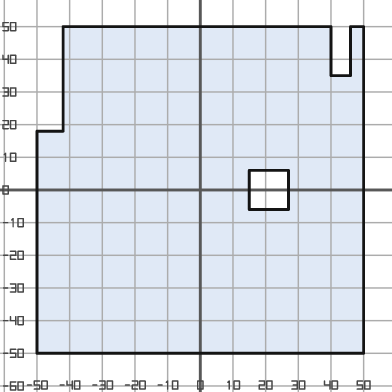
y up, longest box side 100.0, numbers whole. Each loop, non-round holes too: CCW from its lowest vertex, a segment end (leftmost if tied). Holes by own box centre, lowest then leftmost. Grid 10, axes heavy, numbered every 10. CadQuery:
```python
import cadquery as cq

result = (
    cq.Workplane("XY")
    .moveTo(-50.0, -50.0)
    .lineTo(50.0, -50.0)
    .lineTo(50.0, 50.0)
    .lineTo(46.0, 50.0)
    .lineTo(46.0, 35.0)
    .lineTo(40.0, 35.0)
    .lineTo(40.0, 50.0)
    .lineTo(-42.0, 50.0)
    .lineTo(-42.0, 18.0)
    .lineTo(-50.0, 18.0)
    .close()
    .moveTo(15.0, -6.0)
    .lineTo(27.0, -6.0)
    .lineTo(27.0, 6.0)
    .lineTo(15.0, 6.0)
    .close()
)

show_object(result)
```